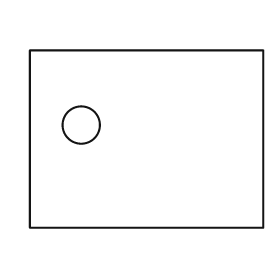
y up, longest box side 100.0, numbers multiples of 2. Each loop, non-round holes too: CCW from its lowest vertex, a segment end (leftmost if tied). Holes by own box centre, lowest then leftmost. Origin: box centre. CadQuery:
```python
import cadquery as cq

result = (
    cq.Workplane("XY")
    .moveTo(-50.0, -38.0)
    .lineTo(50.0, -38.0)
    .lineTo(50.0, 38.0)
    .lineTo(-50.0, 38.0)
    .close()
    .moveTo(-28.0, 6.0)
    .circle(8.0)
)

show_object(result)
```